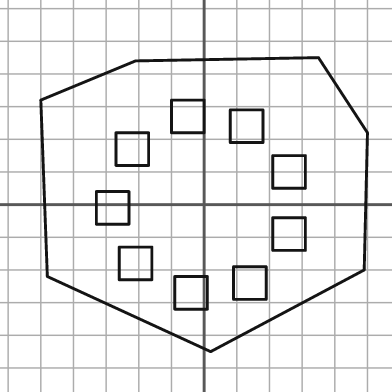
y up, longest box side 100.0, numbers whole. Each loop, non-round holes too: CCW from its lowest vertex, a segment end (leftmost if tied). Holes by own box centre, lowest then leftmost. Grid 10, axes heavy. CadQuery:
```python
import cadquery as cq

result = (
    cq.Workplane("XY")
    .moveTo(2.0, -45.0)
    .lineTo(49.0, -20.0)
    .lineTo(50.0, 22.0)
    .lineTo(35.0, 45.0)
    .lineTo(-21.0, 44.0)
    .lineTo(-50.0, 32.0)
    .lineTo(-48.0, -22.0)
    .close()
    .moveTo(-9.0, -32.0)
    .lineTo(1.0, -32.0)
    .lineTo(1.0, -22.0)
    .lineTo(-9.0, -22.0)
    .close()
    .moveTo(9.0, -29.0)
    .lineTo(19.0, -29.0)
    .lineTo(19.0, -19.0)
    .lineTo(9.0, -19.0)
    .close()
    .moveTo(-26.0, -23.0)
    .lineTo(-16.0, -23.0)
    .lineTo(-16.0, -13.0)
    .lineTo(-26.0, -13.0)
    .close()
    .moveTo(21.0, -14.0)
    .lineTo(31.0, -14.0)
    .lineTo(31.0, -4.0)
    .lineTo(21.0, -4.0)
    .close()
    .moveTo(-33.0, -6.0)
    .lineTo(-23.0, -6.0)
    .lineTo(-23.0, 4.0)
    .lineTo(-33.0, 4.0)
    .close()
    .moveTo(21.0, 5.0)
    .lineTo(31.0, 5.0)
    .lineTo(31.0, 15.0)
    .lineTo(21.0, 15.0)
    .close()
    .moveTo(-27.0, 12.0)
    .lineTo(-17.0, 12.0)
    .lineTo(-17.0, 22.0)
    .lineTo(-27.0, 22.0)
    .close()
    .moveTo(8.0, 19.0)
    .lineTo(18.0, 19.0)
    .lineTo(18.0, 29.0)
    .lineTo(8.0, 29.0)
    .close()
    .moveTo(-10.0, 22.0)
    .lineTo(0.0, 22.0)
    .lineTo(0.0, 32.0)
    .lineTo(-10.0, 32.0)
    .close()
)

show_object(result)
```